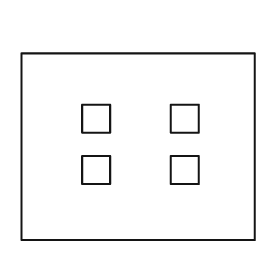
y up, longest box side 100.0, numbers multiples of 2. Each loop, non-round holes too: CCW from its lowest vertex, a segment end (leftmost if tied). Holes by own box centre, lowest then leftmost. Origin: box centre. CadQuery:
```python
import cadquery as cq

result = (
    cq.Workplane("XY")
    .moveTo(-50.0, -40.0)
    .lineTo(50.0, -40.0)
    .lineTo(50.0, 40.0)
    .lineTo(-50.0, 40.0)
    .close()
    .moveTo(-24.0, -16.0)
    .lineTo(-12.0, -16.0)
    .lineTo(-12.0, -4.0)
    .lineTo(-24.0, -4.0)
    .close()
    .moveTo(14.0, -16.0)
    .lineTo(26.0, -16.0)
    .lineTo(26.0, -4.0)
    .lineTo(14.0, -4.0)
    .close()
    .moveTo(-24.0, 6.0)
    .lineTo(-12.0, 6.0)
    .lineTo(-12.0, 18.0)
    .lineTo(-24.0, 18.0)
    .close()
    .moveTo(14.0, 6.0)
    .lineTo(26.0, 6.0)
    .lineTo(26.0, 18.0)
    .lineTo(14.0, 18.0)
    .close()
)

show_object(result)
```